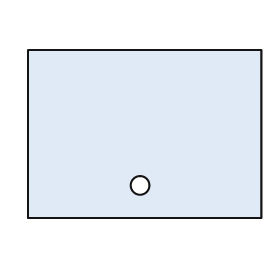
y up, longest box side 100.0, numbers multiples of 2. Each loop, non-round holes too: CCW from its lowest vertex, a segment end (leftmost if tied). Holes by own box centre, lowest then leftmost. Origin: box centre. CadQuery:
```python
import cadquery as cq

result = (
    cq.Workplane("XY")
    .moveTo(-50.0, -36.0)
    .lineTo(50.0, -36.0)
    .lineTo(50.0, 36.0)
    .lineTo(-50.0, 36.0)
    .close()
    .moveTo(-2.0, -22.0)
    .circle(4.0)
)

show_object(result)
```